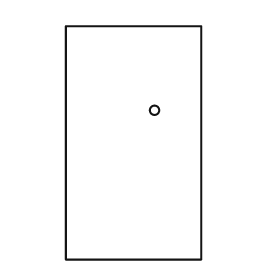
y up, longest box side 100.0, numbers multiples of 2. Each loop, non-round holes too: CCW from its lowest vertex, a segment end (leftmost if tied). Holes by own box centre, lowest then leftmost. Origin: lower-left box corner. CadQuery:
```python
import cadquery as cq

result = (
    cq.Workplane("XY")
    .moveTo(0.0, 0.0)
    .lineTo(58.0, 0.0)
    .lineTo(58.0, 100.0)
    .lineTo(0.0, 100.0)
    .close()
    .moveTo(38.0, 64.0)
    .circle(2.0)
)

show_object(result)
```